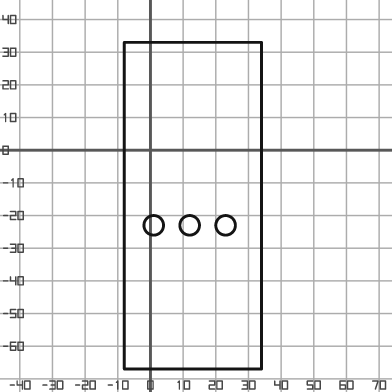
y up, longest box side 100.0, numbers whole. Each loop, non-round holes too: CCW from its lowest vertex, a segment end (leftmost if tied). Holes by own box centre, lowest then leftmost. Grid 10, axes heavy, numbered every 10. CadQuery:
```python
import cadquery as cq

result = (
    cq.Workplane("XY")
    .moveTo(-8.0, -67.0)
    .lineTo(34.0, -67.0)
    .lineTo(34.0, 33.0)
    .lineTo(-8.0, 33.0)
    .close()
    .moveTo(1.0, -23.0)
    .circle(3.0)
    .moveTo(12.0, -23.0)
    .circle(3.0)
    .moveTo(23.0, -23.0)
    .circle(3.0)
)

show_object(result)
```